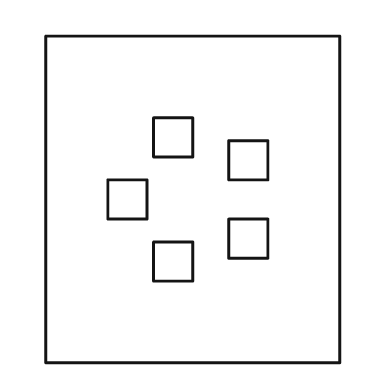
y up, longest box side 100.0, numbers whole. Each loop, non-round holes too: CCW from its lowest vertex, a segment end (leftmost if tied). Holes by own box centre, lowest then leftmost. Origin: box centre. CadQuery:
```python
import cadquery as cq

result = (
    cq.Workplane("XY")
    .moveTo(-45.0, -50.0)
    .lineTo(45.0, -50.0)
    .lineTo(45.0, 50.0)
    .lineTo(-45.0, 50.0)
    .close()
    .moveTo(-12.0, -25.0)
    .lineTo(0.0, -25.0)
    .lineTo(0.0, -13.0)
    .lineTo(-12.0, -13.0)
    .close()
    .moveTo(11.0, -18.0)
    .lineTo(23.0, -18.0)
    .lineTo(23.0, -6.0)
    .lineTo(11.0, -6.0)
    .close()
    .moveTo(-26.0, -6.0)
    .lineTo(-14.0, -6.0)
    .lineTo(-14.0, 6.0)
    .lineTo(-26.0, 6.0)
    .close()
    .moveTo(11.0, 6.0)
    .lineTo(23.0, 6.0)
    .lineTo(23.0, 18.0)
    .lineTo(11.0, 18.0)
    .close()
    .moveTo(-12.0, 13.0)
    .lineTo(0.0, 13.0)
    .lineTo(0.0, 25.0)
    .lineTo(-12.0, 25.0)
    .close()
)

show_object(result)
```